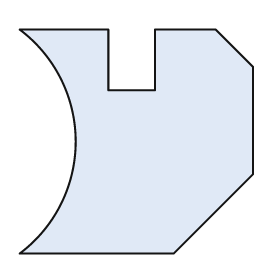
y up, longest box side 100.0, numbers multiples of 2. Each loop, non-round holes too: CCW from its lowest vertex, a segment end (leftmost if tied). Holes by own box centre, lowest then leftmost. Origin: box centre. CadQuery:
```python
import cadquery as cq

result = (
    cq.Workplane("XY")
    .moveTo(-50.0, -48.0)
    .lineTo(16.0, -48.0)
    .lineTo(50.0, -14.0)
    .lineTo(50.0, 32.0)
    .lineTo(34.0, 48.0)
    .lineTo(8.0, 48.0)
    .lineTo(8.0, 22.0)
    .lineTo(-12.0, 22.0)
    .lineTo(-12.0, 48.0)
    .lineTo(-50.0, 48.0)
    .threePointArc((-26.0, 0.0), (-50.0, -48.0))
    .close()
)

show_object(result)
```